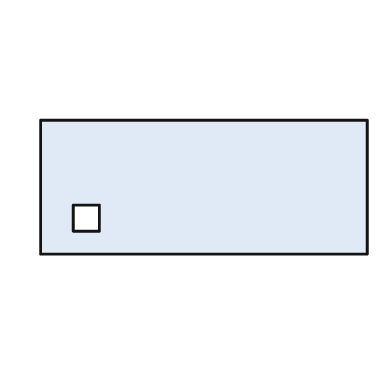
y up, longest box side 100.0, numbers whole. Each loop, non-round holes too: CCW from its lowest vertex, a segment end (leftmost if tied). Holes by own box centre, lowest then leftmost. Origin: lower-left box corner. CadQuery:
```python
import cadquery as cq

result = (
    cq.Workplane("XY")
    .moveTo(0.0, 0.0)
    .lineTo(100.0, 0.0)
    .lineTo(100.0, 41.0)
    .lineTo(0.0, 41.0)
    .close()
    .moveTo(10.0, 7.0)
    .lineTo(18.0, 7.0)
    .lineTo(18.0, 15.0)
    .lineTo(10.0, 15.0)
    .close()
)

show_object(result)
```